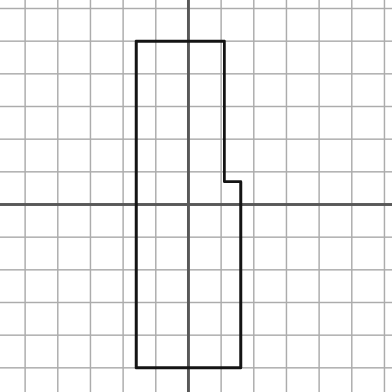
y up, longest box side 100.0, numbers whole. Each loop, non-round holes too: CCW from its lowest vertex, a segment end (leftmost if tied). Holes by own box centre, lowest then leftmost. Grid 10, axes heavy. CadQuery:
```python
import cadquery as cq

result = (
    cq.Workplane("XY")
    .moveTo(-16.0, -50.0)
    .lineTo(16.0, -50.0)
    .lineTo(16.0, 7.0)
    .lineTo(11.0, 7.0)
    .lineTo(11.0, 50.0)
    .lineTo(-16.0, 50.0)
    .close()
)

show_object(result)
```